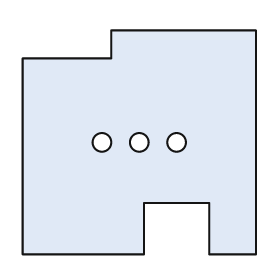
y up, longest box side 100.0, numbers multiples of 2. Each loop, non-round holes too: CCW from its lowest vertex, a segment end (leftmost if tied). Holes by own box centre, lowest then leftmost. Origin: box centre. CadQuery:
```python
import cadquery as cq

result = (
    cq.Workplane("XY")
    .moveTo(-50.0, -48.0)
    .lineTo(2.0, -48.0)
    .lineTo(2.0, -26.0)
    .lineTo(30.0, -26.0)
    .lineTo(30.0, -48.0)
    .lineTo(50.0, -48.0)
    .lineTo(50.0, 48.0)
    .lineTo(-12.0, 48.0)
    .lineTo(-12.0, 36.0)
    .lineTo(-50.0, 36.0)
    .close()
    .moveTo(-16.0, 0.0)
    .circle(4.0)
    .moveTo(0.0, 0.0)
    .circle(4.0)
    .moveTo(16.0, 0.0)
    .circle(4.0)
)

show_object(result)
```